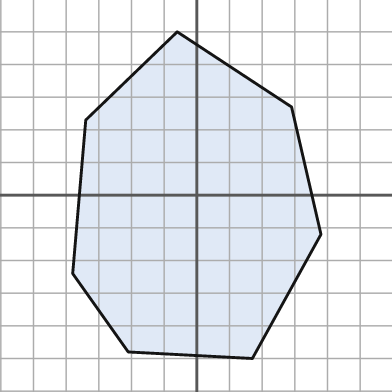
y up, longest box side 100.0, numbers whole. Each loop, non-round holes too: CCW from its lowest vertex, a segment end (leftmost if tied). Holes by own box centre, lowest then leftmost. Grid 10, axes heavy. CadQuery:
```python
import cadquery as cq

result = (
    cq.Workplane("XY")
    .moveTo(17.0, -50.0)
    .lineTo(38.0, -12.0)
    .lineTo(29.0, 27.0)
    .lineTo(-6.0, 50.0)
    .lineTo(-34.0, 23.0)
    .lineTo(-38.0, -24.0)
    .lineTo(-21.0, -48.0)
    .close()
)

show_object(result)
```